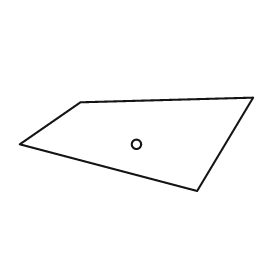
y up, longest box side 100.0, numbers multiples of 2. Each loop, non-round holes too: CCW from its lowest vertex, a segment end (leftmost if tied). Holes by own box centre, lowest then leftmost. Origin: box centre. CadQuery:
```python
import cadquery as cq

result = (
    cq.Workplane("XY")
    .moveTo(26.0, -20.0)
    .lineTo(50.0, 20.0)
    .lineTo(-24.0, 18.0)
    .lineTo(-50.0, 0.0)
    .close()
    .moveTo(0.0, 0.0)
    .circle(2.0)
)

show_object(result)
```